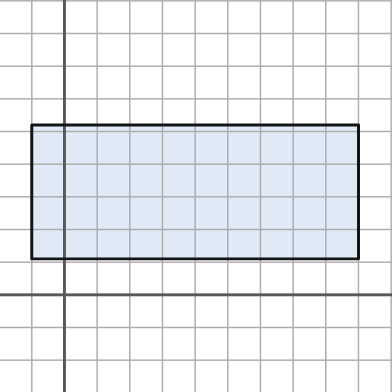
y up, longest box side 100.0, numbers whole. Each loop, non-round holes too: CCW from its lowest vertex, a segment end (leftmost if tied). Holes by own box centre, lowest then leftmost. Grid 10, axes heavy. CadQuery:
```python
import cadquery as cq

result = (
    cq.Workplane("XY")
    .moveTo(-10.0, 11.0)
    .lineTo(90.0, 11.0)
    .lineTo(90.0, 52.0)
    .lineTo(-10.0, 52.0)
    .close()
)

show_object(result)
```